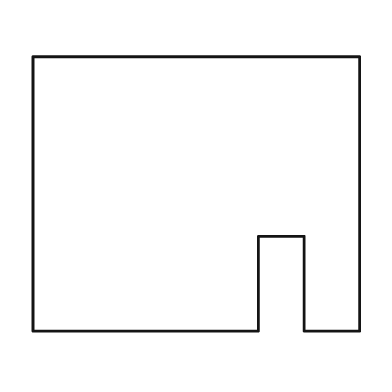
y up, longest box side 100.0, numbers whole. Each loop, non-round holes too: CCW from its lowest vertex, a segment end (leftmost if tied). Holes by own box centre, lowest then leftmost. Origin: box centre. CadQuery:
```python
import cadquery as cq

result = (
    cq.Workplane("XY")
    .moveTo(-50.0, -42.0)
    .lineTo(19.0, -42.0)
    .lineTo(19.0, -13.0)
    .lineTo(33.0, -13.0)
    .lineTo(33.0, -42.0)
    .lineTo(50.0, -42.0)
    .lineTo(50.0, 42.0)
    .lineTo(-50.0, 42.0)
    .close()
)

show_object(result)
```